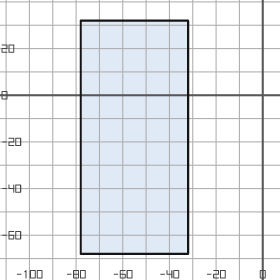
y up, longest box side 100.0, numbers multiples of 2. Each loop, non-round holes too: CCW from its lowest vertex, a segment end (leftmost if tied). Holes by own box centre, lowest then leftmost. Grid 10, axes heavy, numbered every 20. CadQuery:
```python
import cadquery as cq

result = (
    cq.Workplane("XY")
    .moveTo(-78.0, -68.0)
    .lineTo(-32.0, -68.0)
    .lineTo(-32.0, 32.0)
    .lineTo(-78.0, 32.0)
    .close()
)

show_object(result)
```